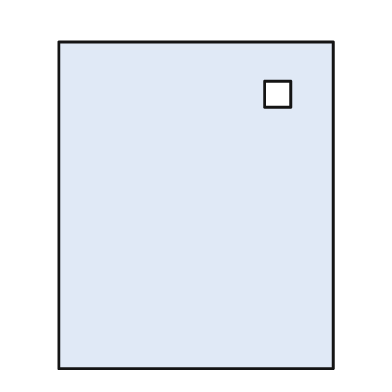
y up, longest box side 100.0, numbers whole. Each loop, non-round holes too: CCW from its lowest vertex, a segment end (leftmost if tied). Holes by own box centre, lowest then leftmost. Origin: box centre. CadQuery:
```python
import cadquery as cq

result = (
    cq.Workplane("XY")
    .moveTo(-42.0, -50.0)
    .lineTo(42.0, -50.0)
    .lineTo(42.0, 50.0)
    .lineTo(-42.0, 50.0)
    .close()
    .moveTo(21.0, 30.0)
    .lineTo(29.0, 30.0)
    .lineTo(29.0, 38.0)
    .lineTo(21.0, 38.0)
    .close()
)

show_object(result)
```